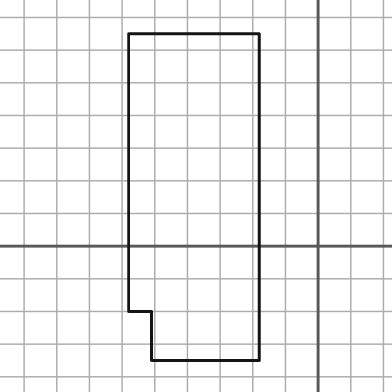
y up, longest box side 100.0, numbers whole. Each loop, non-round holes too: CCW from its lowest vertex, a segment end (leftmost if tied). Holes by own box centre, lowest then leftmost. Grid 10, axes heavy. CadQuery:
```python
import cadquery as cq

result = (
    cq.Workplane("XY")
    .moveTo(-51.0, -35.0)
    .lineTo(-18.0, -35.0)
    .lineTo(-18.0, 65.0)
    .lineTo(-58.0, 65.0)
    .lineTo(-58.0, -20.0)
    .lineTo(-51.0, -20.0)
    .close()
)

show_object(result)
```